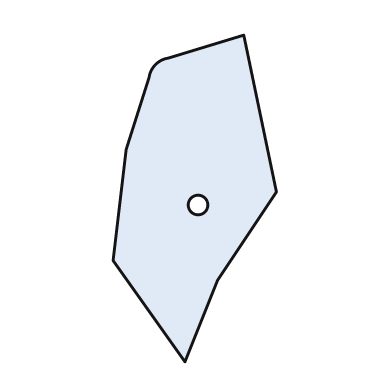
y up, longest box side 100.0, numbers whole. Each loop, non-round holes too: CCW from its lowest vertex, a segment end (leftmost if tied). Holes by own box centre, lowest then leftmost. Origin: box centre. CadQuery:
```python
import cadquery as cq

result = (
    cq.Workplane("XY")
    .moveTo(-3.0, -50.0)
    .lineTo(7.0, -25.0)
    .lineTo(25.0, 2.0)
    .lineTo(15.0, 50.0)
    .lineTo(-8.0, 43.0)
    .threePointArc((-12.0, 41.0), (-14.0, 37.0))
    .lineTo(-21.0, 15.0)
    .lineTo(-25.0, -19.0)
    .close()
    .moveTo(1.0, -2.0)
    .circle(3.0)
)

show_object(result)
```